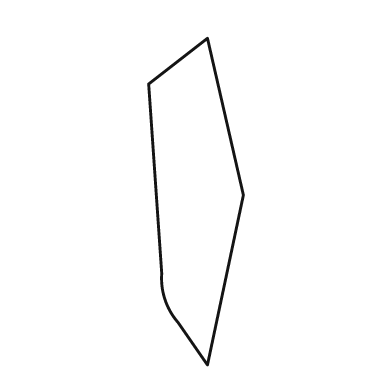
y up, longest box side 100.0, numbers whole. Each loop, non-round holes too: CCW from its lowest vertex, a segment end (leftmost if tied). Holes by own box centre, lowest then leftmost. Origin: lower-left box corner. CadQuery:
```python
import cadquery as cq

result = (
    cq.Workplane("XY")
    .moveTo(18.0, 0.0)
    .lineTo(29.0, 52.0)
    .lineTo(18.0, 100.0)
    .lineTo(0.0, 86.0)
    .lineTo(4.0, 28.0)
    .threePointArc((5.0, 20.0), (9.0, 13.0))
    .close()
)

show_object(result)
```